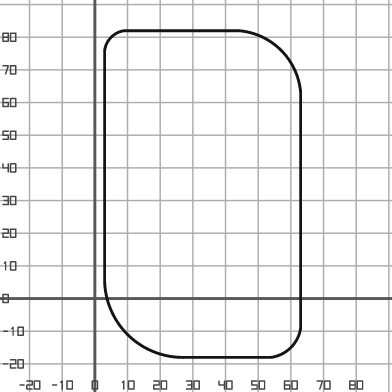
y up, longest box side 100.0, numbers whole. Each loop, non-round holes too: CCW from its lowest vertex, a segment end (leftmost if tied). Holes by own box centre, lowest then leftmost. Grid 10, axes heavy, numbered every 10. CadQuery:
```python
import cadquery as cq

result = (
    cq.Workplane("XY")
    .moveTo(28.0, -18.0)
    .lineTo(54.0, -18.0)
    .threePointArc((60.0, -15.0), (63.0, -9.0))
    .lineTo(63.0, 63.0)
    .threePointArc((57.0, 76.0), (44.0, 82.0))
    .lineTo(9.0, 82.0)
    .threePointArc((5.0, 80.0), (3.0, 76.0))
    .lineTo(3.0, 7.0)
    .threePointArc((10.0, -11.0), (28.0, -18.0))
    .close()
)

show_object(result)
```